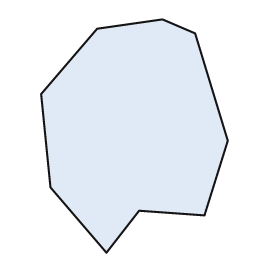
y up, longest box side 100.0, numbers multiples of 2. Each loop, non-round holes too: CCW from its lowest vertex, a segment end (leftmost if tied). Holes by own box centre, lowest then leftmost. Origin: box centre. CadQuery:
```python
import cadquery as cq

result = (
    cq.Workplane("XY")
    .moveTo(-12.0, -50.0)
    .lineTo(2.0, -32.0)
    .lineTo(30.0, -34.0)
    .lineTo(40.0, -2.0)
    .lineTo(26.0, 44.0)
    .lineTo(12.0, 50.0)
    .lineTo(-16.0, 46.0)
    .lineTo(-40.0, 18.0)
    .lineTo(-36.0, -22.0)
    .close()
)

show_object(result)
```